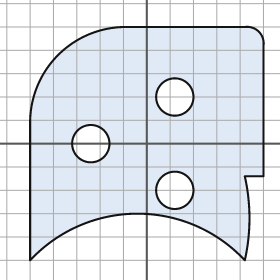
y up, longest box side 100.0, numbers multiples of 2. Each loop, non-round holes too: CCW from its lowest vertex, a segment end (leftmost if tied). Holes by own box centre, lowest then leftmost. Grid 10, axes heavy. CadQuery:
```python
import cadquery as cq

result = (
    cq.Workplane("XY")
    .moveTo(-50.0, -50.0)
    .threePointArc((-4.0, -30.0), (42.0, -50.0))
    .threePointArc((44.0, -32.0), (42.0, -14.0))
    .lineTo(50.0, -14.0)
    .lineTo(50.0, 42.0)
    .threePointArc((48.0, 48.0), (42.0, 50.0))
    .lineTo(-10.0, 50.0)
    .threePointArc((-38.0, 38.0), (-50.0, 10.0))
    .close()
    .moveTo(12.0, -20.0)
    .circle(8.0)
    .moveTo(-24.0, 0.0)
    .circle(8.0)
    .moveTo(12.0, 20.0)
    .circle(8.0)
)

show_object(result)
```